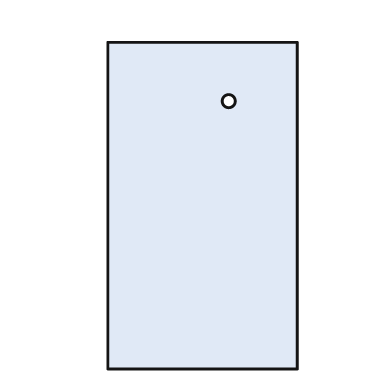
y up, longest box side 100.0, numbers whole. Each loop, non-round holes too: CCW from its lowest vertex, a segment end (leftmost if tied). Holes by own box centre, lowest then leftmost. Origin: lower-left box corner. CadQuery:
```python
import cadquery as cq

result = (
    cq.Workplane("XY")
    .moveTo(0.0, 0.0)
    .lineTo(58.0, 0.0)
    .lineTo(58.0, 100.0)
    .lineTo(0.0, 100.0)
    .close()
    .moveTo(37.0, 82.0)
    .circle(2.0)
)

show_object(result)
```